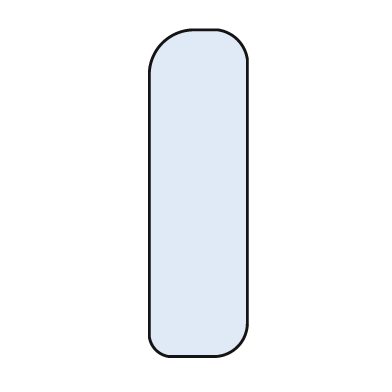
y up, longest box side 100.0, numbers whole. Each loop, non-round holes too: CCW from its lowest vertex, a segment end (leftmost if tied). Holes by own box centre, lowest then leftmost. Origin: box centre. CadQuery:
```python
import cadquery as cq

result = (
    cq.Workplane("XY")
    .moveTo(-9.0, -50.0)
    .lineTo(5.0, -50.0)
    .threePointArc((12.0, -47.0), (15.0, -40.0))
    .lineTo(15.0, 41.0)
    .threePointArc((12.0, 47.0), (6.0, 50.0))
    .lineTo(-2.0, 50.0)
    .threePointArc((-11.0, 46.0), (-15.0, 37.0))
    .lineTo(-15.0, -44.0)
    .threePointArc((-13.0, -48.0), (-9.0, -50.0))
    .close()
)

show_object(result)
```